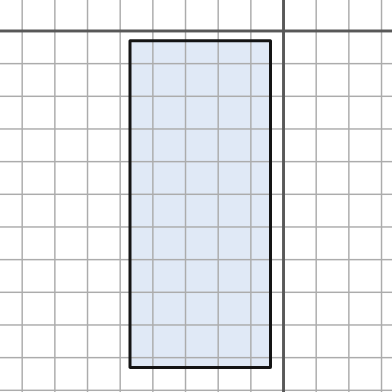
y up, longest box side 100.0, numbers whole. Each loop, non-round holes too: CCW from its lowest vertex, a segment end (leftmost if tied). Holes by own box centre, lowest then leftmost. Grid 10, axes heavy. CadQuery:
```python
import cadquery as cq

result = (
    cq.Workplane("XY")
    .moveTo(-47.0, -103.0)
    .lineTo(-4.0, -103.0)
    .lineTo(-4.0, -3.0)
    .lineTo(-47.0, -3.0)
    .close()
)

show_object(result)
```